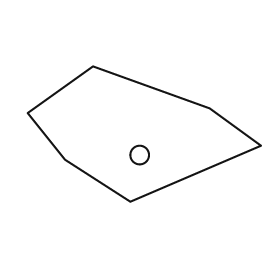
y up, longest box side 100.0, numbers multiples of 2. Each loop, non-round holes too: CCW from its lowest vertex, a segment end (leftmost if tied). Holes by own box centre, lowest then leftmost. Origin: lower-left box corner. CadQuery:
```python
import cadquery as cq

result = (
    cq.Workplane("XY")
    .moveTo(44.0, 0.0)
    .lineTo(100.0, 24.0)
    .lineTo(78.0, 40.0)
    .lineTo(28.0, 58.0)
    .lineTo(0.0, 38.0)
    .lineTo(16.0, 18.0)
    .close()
    .moveTo(48.0, 20.0)
    .circle(4.0)
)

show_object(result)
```